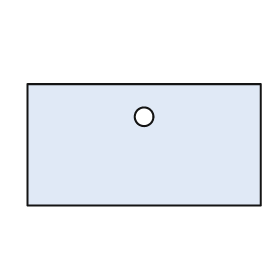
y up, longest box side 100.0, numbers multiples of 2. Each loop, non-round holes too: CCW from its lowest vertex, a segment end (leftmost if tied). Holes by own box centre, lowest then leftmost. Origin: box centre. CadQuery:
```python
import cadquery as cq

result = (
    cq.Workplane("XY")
    .moveTo(-50.0, -26.0)
    .lineTo(50.0, -26.0)
    .lineTo(50.0, 26.0)
    .lineTo(-50.0, 26.0)
    .close()
    .moveTo(0.0, 12.0)
    .circle(4.0)
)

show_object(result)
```